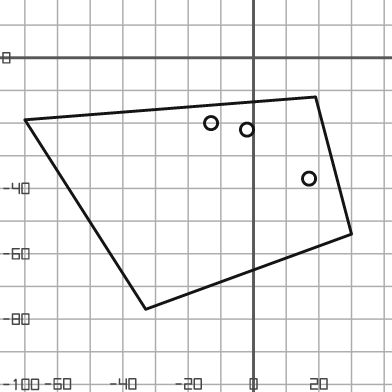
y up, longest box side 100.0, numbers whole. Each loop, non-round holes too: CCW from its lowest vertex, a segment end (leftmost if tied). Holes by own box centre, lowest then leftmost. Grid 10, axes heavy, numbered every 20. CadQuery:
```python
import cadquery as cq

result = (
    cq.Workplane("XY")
    .moveTo(-33.0, -77.0)
    .lineTo(30.0, -54.0)
    .lineTo(19.0, -12.0)
    .lineTo(-70.0, -19.0)
    .close()
    .moveTo(17.0, -37.0)
    .circle(2.0)
    .moveTo(-2.0, -22.0)
    .circle(2.0)
    .moveTo(-13.0, -20.0)
    .circle(2.0)
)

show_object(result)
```